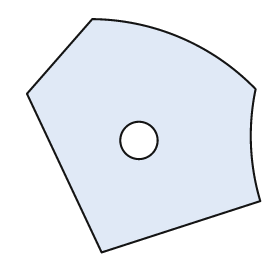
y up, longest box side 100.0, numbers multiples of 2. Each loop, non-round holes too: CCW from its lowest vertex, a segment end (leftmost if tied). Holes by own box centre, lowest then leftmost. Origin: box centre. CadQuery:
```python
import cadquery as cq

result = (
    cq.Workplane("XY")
    .moveTo(-18.0, -50.0)
    .lineTo(50.0, -28.0)
    .threePointArc((46.0, -4.0), (48.0, 20.0))
    .threePointArc((16.0, 42.0), (-22.0, 50.0))
    .lineTo(-50.0, 18.0)
    .close()
    .moveTo(-2.0, -2.0)
    .circle(8.0)
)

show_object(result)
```